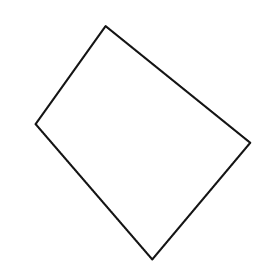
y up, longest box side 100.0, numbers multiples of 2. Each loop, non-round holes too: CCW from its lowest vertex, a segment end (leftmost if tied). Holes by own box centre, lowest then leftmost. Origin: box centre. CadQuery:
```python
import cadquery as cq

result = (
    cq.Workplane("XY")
    .moveTo(4.0, -50.0)
    .lineTo(46.0, 0.0)
    .lineTo(-16.0, 50.0)
    .lineTo(-46.0, 8.0)
    .close()
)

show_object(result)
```